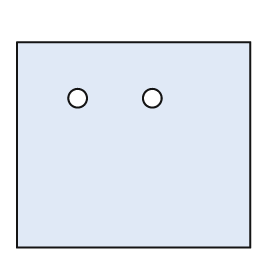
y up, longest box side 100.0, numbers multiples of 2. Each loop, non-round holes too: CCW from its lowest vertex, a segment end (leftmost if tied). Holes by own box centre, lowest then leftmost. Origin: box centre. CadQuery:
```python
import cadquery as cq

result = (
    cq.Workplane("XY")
    .moveTo(-50.0, -44.0)
    .lineTo(50.0, -44.0)
    .lineTo(50.0, 44.0)
    .lineTo(-50.0, 44.0)
    .close()
    .moveTo(-24.0, 20.0)
    .circle(4.0)
    .moveTo(8.0, 20.0)
    .circle(4.0)
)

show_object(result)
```